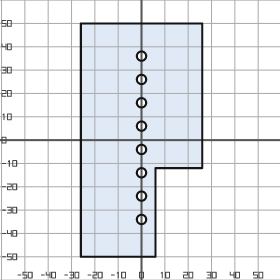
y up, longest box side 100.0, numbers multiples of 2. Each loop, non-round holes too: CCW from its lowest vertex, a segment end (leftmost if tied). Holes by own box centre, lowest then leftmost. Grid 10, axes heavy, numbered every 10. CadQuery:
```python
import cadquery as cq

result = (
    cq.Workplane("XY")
    .moveTo(-26.0, -50.0)
    .lineTo(6.0, -50.0)
    .lineTo(6.0, -12.0)
    .lineTo(26.0, -12.0)
    .lineTo(26.0, 50.0)
    .lineTo(-26.0, 50.0)
    .close()
    .moveTo(0.0, -34.0)
    .circle(2.0)
    .moveTo(0.0, -24.0)
    .circle(2.0)
    .moveTo(0.0, -14.0)
    .circle(2.0)
    .moveTo(0.0, -4.0)
    .circle(2.0)
    .moveTo(0.0, 6.0)
    .circle(2.0)
    .moveTo(0.0, 16.0)
    .circle(2.0)
    .moveTo(0.0, 26.0)
    .circle(2.0)
    .moveTo(0.0, 36.0)
    .circle(2.0)
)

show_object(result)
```